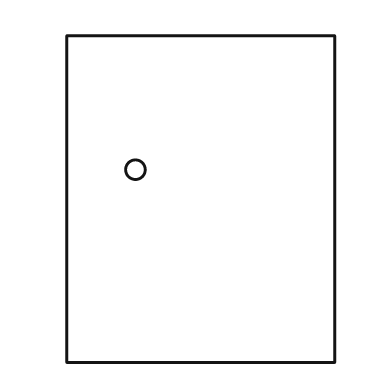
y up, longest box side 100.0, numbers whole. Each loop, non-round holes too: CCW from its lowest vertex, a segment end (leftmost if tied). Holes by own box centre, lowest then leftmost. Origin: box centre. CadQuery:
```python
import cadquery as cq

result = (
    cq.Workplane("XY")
    .moveTo(-41.0, -50.0)
    .lineTo(41.0, -50.0)
    .lineTo(41.0, 50.0)
    .lineTo(-41.0, 50.0)
    .close()
    .moveTo(-20.0, 9.0)
    .circle(3.0)
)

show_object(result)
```